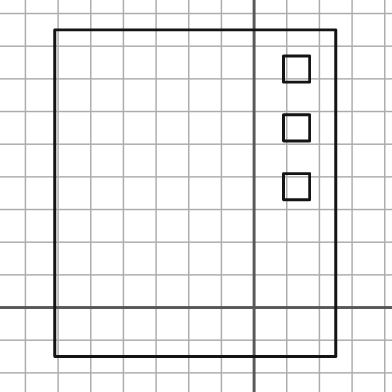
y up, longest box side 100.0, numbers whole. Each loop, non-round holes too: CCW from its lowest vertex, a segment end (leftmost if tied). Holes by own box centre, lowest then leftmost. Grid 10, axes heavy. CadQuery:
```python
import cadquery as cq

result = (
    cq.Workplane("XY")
    .moveTo(-61.0, -15.0)
    .lineTo(25.0, -15.0)
    .lineTo(25.0, 85.0)
    .lineTo(-61.0, 85.0)
    .close()
    .moveTo(9.0, 33.0)
    .lineTo(17.0, 33.0)
    .lineTo(17.0, 41.0)
    .lineTo(9.0, 41.0)
    .close()
    .moveTo(9.0, 51.0)
    .lineTo(17.0, 51.0)
    .lineTo(17.0, 59.0)
    .lineTo(9.0, 59.0)
    .close()
    .moveTo(9.0, 69.0)
    .lineTo(17.0, 69.0)
    .lineTo(17.0, 77.0)
    .lineTo(9.0, 77.0)
    .close()
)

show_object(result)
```